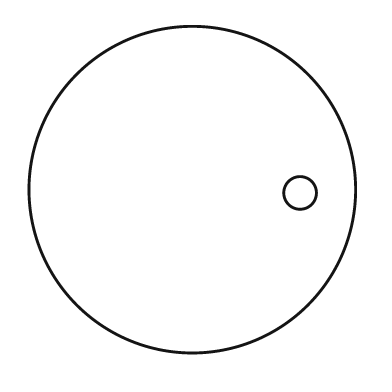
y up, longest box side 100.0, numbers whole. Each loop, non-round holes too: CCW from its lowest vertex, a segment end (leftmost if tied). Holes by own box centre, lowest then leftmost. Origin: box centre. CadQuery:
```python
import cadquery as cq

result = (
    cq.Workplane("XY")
    .moveTo(0.0, 0.0)
    .circle(50.0)
    .moveTo(33.0, -1.0)
    .circle(5.0)
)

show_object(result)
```